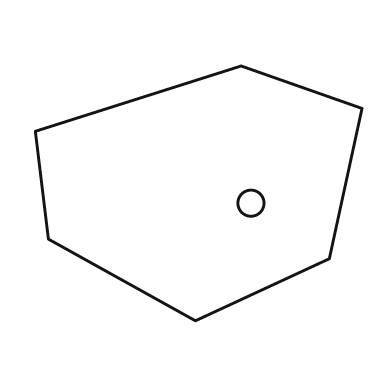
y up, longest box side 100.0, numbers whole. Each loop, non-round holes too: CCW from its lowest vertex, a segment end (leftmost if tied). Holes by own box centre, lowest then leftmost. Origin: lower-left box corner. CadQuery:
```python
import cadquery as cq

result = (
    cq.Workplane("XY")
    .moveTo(49.0, 0.0)
    .lineTo(90.0, 19.0)
    .lineTo(100.0, 65.0)
    .lineTo(63.0, 78.0)
    .lineTo(0.0, 58.0)
    .lineTo(4.0, 25.0)
    .close()
    .moveTo(66.0, 36.0)
    .circle(4.0)
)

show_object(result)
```